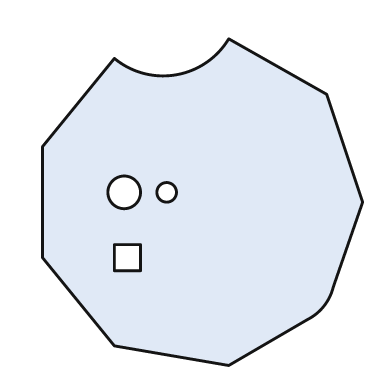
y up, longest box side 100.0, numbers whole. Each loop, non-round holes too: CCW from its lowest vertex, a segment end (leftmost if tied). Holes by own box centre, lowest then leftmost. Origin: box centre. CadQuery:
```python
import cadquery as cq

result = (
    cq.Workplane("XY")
    .moveTo(8.0, -50.0)
    .lineTo(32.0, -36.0)
    .threePointArc((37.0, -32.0), (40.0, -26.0))
    .lineTo(49.0, 0.0)
    .lineTo(38.0, 33.0)
    .lineTo(8.0, 50.0)
    .threePointArc((-8.0, 39.0), (-27.0, 44.0))
    .lineTo(-49.0, 17.0)
    .lineTo(-49.0, -17.0)
    .lineTo(-27.0, -44.0)
    .close()
    .moveTo(-27.0, -21.0)
    .lineTo(-19.0, -21.0)
    .lineTo(-19.0, -13.0)
    .lineTo(-27.0, -13.0)
    .close()
    .moveTo(-24.0, 3.0)
    .circle(5.0)
    .moveTo(-11.0, 3.0)
    .circle(3.0)
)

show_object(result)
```